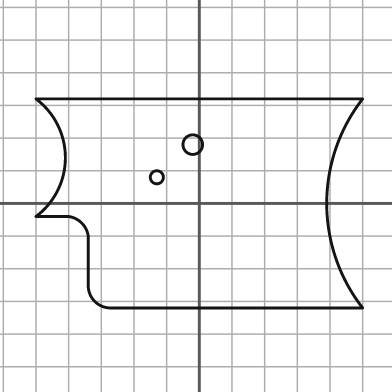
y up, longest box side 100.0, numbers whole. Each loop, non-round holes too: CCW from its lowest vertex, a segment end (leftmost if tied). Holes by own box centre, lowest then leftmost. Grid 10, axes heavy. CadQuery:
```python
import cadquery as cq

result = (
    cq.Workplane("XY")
    .moveTo(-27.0, -32.0)
    .lineTo(50.0, -32.0)
    .threePointArc((39.0, 0.0), (50.0, 32.0))
    .lineTo(-50.0, 32.0)
    .threePointArc((-41.0, 14.0), (-50.0, -4.0))
    .lineTo(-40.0, -4.0)
    .threePointArc((-36.0, -6.0), (-34.0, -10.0))
    .lineTo(-34.0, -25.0)
    .threePointArc((-32.0, -30.0), (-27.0, -32.0))
    .close()
    .moveTo(-13.0, 8.0)
    .circle(2.0)
    .moveTo(-2.0, 18.0)
    .circle(3.0)
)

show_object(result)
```